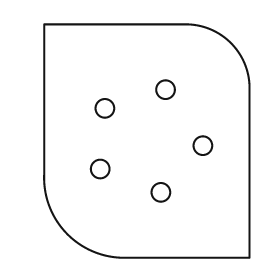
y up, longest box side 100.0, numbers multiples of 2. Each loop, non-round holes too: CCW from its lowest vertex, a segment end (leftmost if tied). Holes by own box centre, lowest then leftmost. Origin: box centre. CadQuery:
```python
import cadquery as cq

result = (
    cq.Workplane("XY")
    .moveTo(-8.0, -50.0)
    .lineTo(44.0, -50.0)
    .lineTo(44.0, 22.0)
    .threePointArc((36.0, 42.0), (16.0, 50.0))
    .lineTo(-44.0, 50.0)
    .lineTo(-44.0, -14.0)
    .threePointArc((-34.0, -40.0), (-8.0, -50.0))
    .close()
    .moveTo(6.0, -22.0)
    .circle(4.0)
    .moveTo(-20.0, -12.0)
    .circle(4.0)
    .moveTo(24.0, -2.0)
    .circle(4.0)
    .moveTo(-18.0, 14.0)
    .circle(4.0)
    .moveTo(8.0, 22.0)
    .circle(4.0)
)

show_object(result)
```